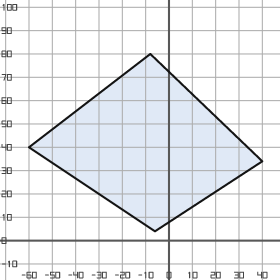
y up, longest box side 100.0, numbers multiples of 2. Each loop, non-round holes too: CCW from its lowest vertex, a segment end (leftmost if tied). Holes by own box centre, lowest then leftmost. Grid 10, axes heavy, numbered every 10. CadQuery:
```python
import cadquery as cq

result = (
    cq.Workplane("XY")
    .moveTo(-6.0, 4.0)
    .lineTo(40.0, 34.0)
    .lineTo(-8.0, 80.0)
    .lineTo(-60.0, 40.0)
    .close()
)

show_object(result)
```